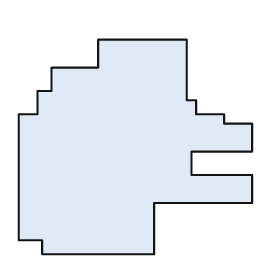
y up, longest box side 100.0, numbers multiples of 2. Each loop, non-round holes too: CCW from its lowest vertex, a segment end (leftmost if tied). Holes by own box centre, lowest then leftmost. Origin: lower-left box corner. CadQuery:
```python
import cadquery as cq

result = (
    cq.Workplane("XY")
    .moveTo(10.0, 0.0)
    .lineTo(58.0, 0.0)
    .lineTo(58.0, 22.0)
    .lineTo(100.0, 22.0)
    .lineTo(100.0, 34.0)
    .lineTo(74.0, 34.0)
    .lineTo(74.0, 44.0)
    .lineTo(100.0, 44.0)
    .lineTo(100.0, 56.0)
    .lineTo(88.0, 56.0)
    .lineTo(88.0, 60.0)
    .lineTo(76.0, 60.0)
    .lineTo(76.0, 66.0)
    .lineTo(72.0, 66.0)
    .lineTo(72.0, 92.0)
    .lineTo(34.0, 92.0)
    .lineTo(34.0, 80.0)
    .lineTo(14.0, 80.0)
    .lineTo(14.0, 70.0)
    .lineTo(8.0, 70.0)
    .lineTo(8.0, 60.0)
    .lineTo(0.0, 60.0)
    .lineTo(0.0, 6.0)
    .lineTo(10.0, 6.0)
    .close()
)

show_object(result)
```